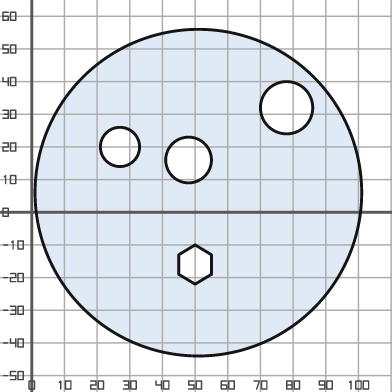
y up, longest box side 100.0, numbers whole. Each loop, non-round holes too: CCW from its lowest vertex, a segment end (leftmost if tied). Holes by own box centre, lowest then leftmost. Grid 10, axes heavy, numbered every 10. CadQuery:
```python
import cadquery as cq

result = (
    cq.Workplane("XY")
    .moveTo(51.0, 6.0)
    .circle(50.0)
    .moveTo(50.0, -22.0)
    .lineTo(55.0, -19.0)
    .lineTo(55.0, -13.0)
    .lineTo(50.0, -10.0)
    .lineTo(45.0, -13.0)
    .lineTo(45.0, -19.0)
    .close()
    .moveTo(48.0, 16.0)
    .circle(7.0)
    .moveTo(27.0, 20.0)
    .circle(6.0)
    .moveTo(78.0, 32.0)
    .circle(8.0)
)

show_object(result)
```